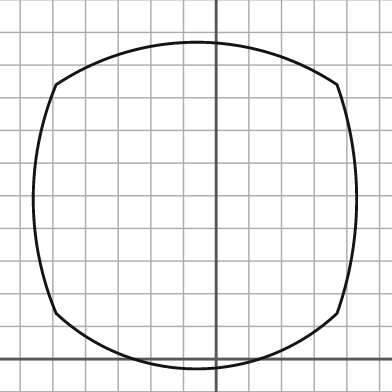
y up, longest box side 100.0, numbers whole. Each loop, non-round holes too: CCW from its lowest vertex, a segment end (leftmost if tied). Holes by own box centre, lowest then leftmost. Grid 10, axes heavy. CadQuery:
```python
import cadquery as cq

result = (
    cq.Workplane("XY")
    .moveTo(-49.0, 14.0)
    .threePointArc((-6.0, -3.0), (37.0, 14.0))
    .threePointArc((43.0, 49.0), (37.0, 84.0))
    .threePointArc((-6.0, 97.0), (-49.0, 84.0))
    .threePointArc((-56.0, 49.0), (-49.0, 14.0))
    .close()
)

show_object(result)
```